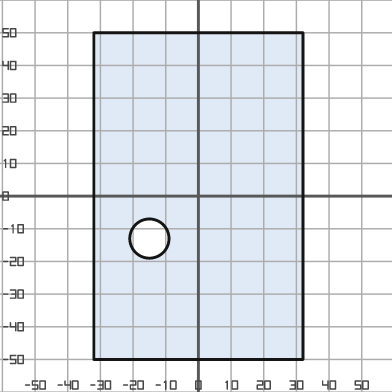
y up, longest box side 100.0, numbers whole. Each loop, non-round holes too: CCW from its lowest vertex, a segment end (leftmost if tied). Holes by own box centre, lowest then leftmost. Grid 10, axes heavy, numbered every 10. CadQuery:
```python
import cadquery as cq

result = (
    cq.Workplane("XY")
    .moveTo(-32.0, -50.0)
    .lineTo(32.0, -50.0)
    .lineTo(32.0, 50.0)
    .lineTo(-32.0, 50.0)
    .close()
    .moveTo(-15.0, -13.0)
    .circle(6.0)
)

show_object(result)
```